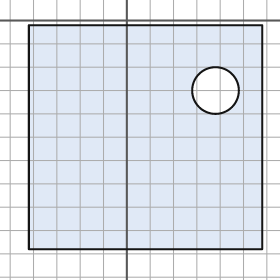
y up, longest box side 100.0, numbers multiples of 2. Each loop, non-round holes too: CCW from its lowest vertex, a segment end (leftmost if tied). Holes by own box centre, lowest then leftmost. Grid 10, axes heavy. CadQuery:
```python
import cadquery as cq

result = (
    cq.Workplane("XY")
    .moveTo(-42.0, -98.0)
    .lineTo(58.0, -98.0)
    .lineTo(58.0, -2.0)
    .lineTo(-42.0, -2.0)
    .close()
    .moveTo(38.0, -30.0)
    .circle(10.0)
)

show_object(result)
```